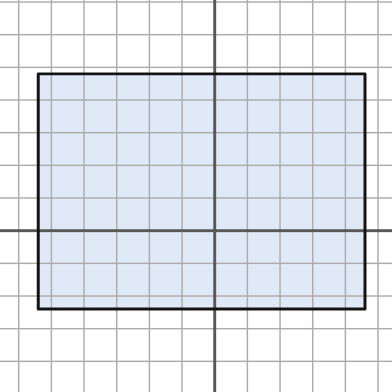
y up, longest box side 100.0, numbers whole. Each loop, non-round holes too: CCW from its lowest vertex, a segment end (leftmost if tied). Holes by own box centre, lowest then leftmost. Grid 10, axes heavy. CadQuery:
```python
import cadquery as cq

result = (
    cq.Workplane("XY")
    .moveTo(-54.0, -24.0)
    .lineTo(46.0, -24.0)
    .lineTo(46.0, 48.0)
    .lineTo(-54.0, 48.0)
    .close()
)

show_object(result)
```